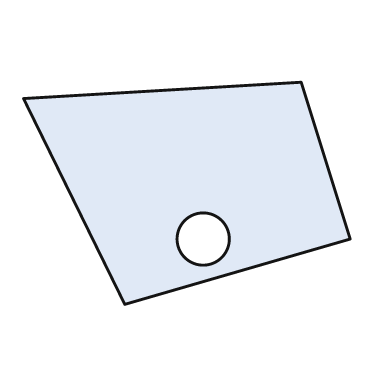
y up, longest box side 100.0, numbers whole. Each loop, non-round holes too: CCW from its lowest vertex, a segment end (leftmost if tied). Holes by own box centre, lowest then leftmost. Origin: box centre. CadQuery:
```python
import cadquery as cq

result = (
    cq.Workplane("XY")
    .moveTo(-19.0, -34.0)
    .lineTo(50.0, -14.0)
    .lineTo(35.0, 34.0)
    .lineTo(-50.0, 29.0)
    .close()
    .moveTo(5.0, -14.0)
    .circle(8.0)
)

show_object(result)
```